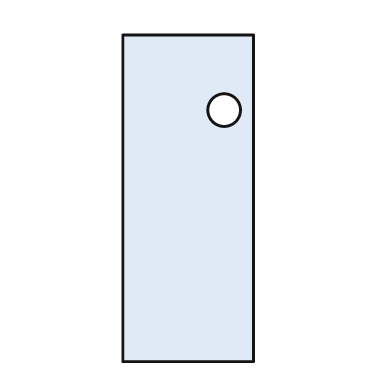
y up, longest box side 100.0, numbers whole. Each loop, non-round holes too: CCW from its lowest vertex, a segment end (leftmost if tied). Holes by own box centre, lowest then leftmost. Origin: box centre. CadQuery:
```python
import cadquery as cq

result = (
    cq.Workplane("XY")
    .moveTo(-20.0, -50.0)
    .lineTo(20.0, -50.0)
    .lineTo(20.0, 50.0)
    .lineTo(-20.0, 50.0)
    .close()
    .moveTo(11.0, 27.0)
    .circle(5.0)
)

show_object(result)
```